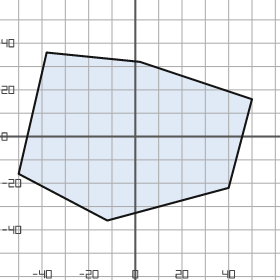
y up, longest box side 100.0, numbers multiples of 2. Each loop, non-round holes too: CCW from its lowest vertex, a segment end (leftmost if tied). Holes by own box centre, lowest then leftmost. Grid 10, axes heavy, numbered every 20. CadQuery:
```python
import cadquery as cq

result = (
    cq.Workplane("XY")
    .moveTo(-12.0, -36.0)
    .lineTo(40.0, -22.0)
    .lineTo(50.0, 16.0)
    .lineTo(2.0, 32.0)
    .lineTo(-38.0, 36.0)
    .lineTo(-50.0, -16.0)
    .close()
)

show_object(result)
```